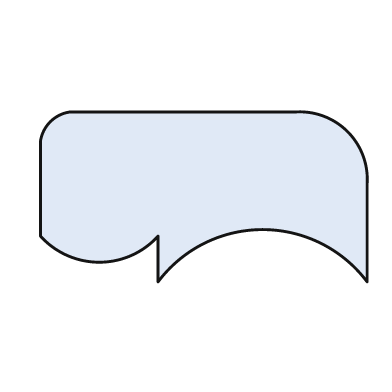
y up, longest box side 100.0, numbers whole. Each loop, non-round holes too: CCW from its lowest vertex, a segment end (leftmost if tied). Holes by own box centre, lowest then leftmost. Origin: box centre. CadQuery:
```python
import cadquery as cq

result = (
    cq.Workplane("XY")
    .moveTo(-14.0, -26.0)
    .threePointArc((18.0, -10.0), (50.0, -26.0))
    .lineTo(50.0, 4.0)
    .threePointArc((44.0, 20.0), (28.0, 26.0))
    .lineTo(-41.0, 26.0)
    .threePointArc((-47.0, 23.0), (-50.0, 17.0))
    .lineTo(-50.0, -12.0)
    .threePointArc((-32.0, -20.0), (-14.0, -12.0))
    .close()
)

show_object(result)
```